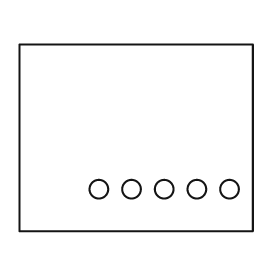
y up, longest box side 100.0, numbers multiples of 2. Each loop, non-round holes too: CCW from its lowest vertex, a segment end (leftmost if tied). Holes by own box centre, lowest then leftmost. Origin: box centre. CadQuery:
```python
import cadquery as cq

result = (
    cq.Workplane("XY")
    .moveTo(-50.0, -40.0)
    .lineTo(50.0, -40.0)
    .lineTo(50.0, 40.0)
    .lineTo(-50.0, 40.0)
    .close()
    .moveTo(-16.0, -22.0)
    .circle(4.0)
    .moveTo(-2.0, -22.0)
    .circle(4.0)
    .moveTo(12.0, -22.0)
    .circle(4.0)
    .moveTo(26.0, -22.0)
    .circle(4.0)
    .moveTo(40.0, -22.0)
    .circle(4.0)
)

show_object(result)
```